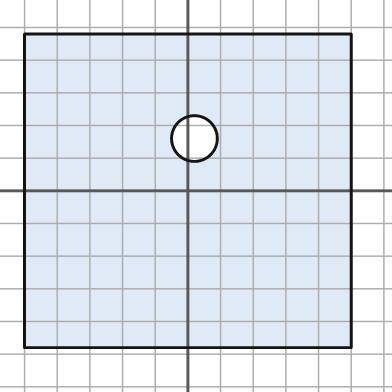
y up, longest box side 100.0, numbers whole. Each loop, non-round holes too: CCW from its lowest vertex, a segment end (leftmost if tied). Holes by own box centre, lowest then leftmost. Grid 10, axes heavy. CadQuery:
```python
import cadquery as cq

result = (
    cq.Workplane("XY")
    .moveTo(-50.0, -48.0)
    .lineTo(50.0, -48.0)
    .lineTo(50.0, 48.0)
    .lineTo(-50.0, 48.0)
    .close()
    .moveTo(2.0, 16.0)
    .circle(7.0)
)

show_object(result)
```